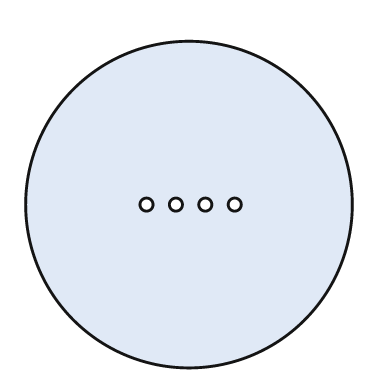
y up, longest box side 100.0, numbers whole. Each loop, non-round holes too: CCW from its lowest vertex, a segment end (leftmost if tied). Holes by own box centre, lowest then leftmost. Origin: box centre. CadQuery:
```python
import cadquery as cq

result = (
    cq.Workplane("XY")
    .moveTo(0.0, 0.0)
    .circle(50.0)
    .moveTo(-13.0, 0.0)
    .circle(2.0)
    .moveTo(-4.0, 0.0)
    .circle(2.0)
    .moveTo(5.0, 0.0)
    .circle(2.0)
    .moveTo(14.0, 0.0)
    .circle(2.0)
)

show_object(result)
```